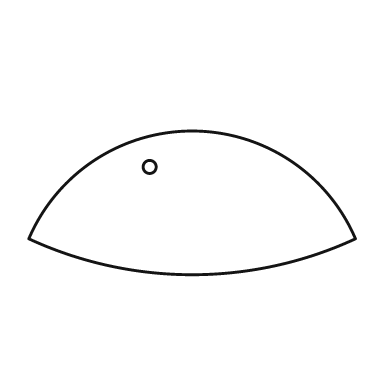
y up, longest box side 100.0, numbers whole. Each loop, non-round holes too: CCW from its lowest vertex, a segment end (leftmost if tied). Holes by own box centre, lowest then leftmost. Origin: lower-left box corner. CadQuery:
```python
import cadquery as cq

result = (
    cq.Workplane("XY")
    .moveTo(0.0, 11.0)
    .threePointArc((50.0, 0.0), (100.0, 11.0))
    .threePointArc((50.0, 44.0), (0.0, 11.0))
    .close()
    .moveTo(37.0, 33.0)
    .circle(2.0)
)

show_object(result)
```